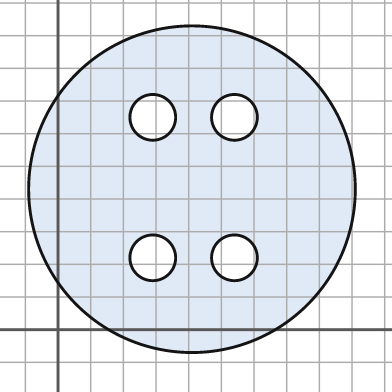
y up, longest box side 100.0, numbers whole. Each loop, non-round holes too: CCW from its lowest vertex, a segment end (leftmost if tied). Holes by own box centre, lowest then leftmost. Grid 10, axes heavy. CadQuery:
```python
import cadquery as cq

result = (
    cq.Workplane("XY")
    .moveTo(41.0, 43.0)
    .circle(50.0)
    .moveTo(29.0, 22.0)
    .circle(7.0)
    .moveTo(54.0, 22.0)
    .circle(7.0)
    .moveTo(29.0, 65.0)
    .circle(7.0)
    .moveTo(54.0, 65.0)
    .circle(7.0)
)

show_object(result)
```